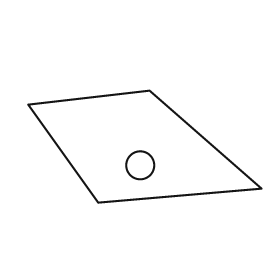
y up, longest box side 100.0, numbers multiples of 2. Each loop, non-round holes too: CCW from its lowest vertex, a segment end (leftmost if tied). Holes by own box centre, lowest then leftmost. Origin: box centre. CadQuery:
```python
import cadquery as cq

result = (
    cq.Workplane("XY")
    .moveTo(-20.0, -24.0)
    .lineTo(50.0, -18.0)
    .lineTo(2.0, 24.0)
    .lineTo(-50.0, 18.0)
    .close()
    .moveTo(-2.0, -8.0)
    .circle(6.0)
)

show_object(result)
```